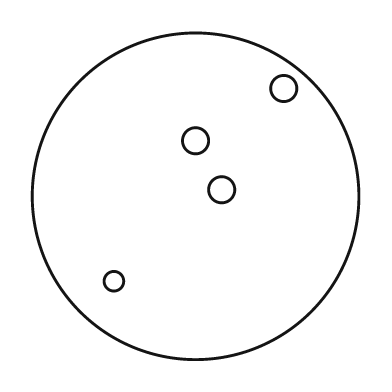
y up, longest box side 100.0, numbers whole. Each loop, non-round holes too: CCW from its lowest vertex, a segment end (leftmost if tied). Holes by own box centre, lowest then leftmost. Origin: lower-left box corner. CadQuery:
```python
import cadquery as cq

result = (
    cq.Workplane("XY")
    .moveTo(50.0, 50.0)
    .circle(50.0)
    .moveTo(25.0, 24.0)
    .circle(3.0)
    .moveTo(58.0, 52.0)
    .circle(4.0)
    .moveTo(50.0, 67.0)
    .circle(4.0)
    .moveTo(77.0, 83.0)
    .circle(4.0)
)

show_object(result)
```